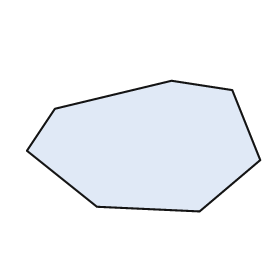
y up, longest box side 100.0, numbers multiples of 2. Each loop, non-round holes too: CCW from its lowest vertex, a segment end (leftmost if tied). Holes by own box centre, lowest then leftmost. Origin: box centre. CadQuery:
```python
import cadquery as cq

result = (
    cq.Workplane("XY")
    .moveTo(24.0, -28.0)
    .lineTo(50.0, -6.0)
    .lineTo(38.0, 24.0)
    .lineTo(12.0, 28.0)
    .lineTo(-38.0, 16.0)
    .lineTo(-50.0, -2.0)
    .lineTo(-20.0, -26.0)
    .close()
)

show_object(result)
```